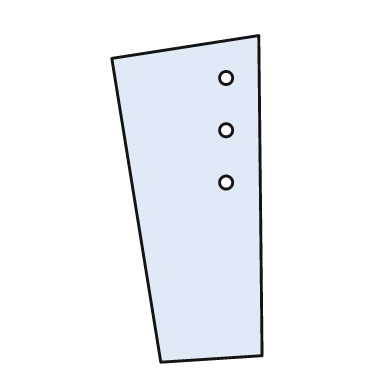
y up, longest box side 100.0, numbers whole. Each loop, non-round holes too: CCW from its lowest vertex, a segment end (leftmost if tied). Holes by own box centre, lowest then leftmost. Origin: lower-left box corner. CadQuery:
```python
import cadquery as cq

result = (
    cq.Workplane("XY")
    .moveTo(15.0, 0.0)
    .lineTo(46.0, 2.0)
    .lineTo(45.0, 100.0)
    .lineTo(0.0, 93.0)
    .close()
    .moveTo(35.0, 55.0)
    .circle(2.0)
    .moveTo(35.0, 71.0)
    .circle(2.0)
    .moveTo(35.0, 87.0)
    .circle(2.0)
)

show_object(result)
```